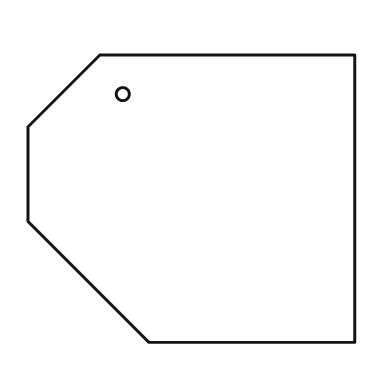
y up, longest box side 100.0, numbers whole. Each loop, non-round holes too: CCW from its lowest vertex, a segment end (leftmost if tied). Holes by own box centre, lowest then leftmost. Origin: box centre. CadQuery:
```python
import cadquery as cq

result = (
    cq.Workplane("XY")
    .moveTo(-13.0, -44.0)
    .lineTo(50.0, -44.0)
    .lineTo(50.0, 44.0)
    .lineTo(-28.0, 44.0)
    .lineTo(-50.0, 22.0)
    .lineTo(-50.0, -7.0)
    .close()
    .moveTo(-21.0, 32.0)
    .circle(2.0)
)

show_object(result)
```